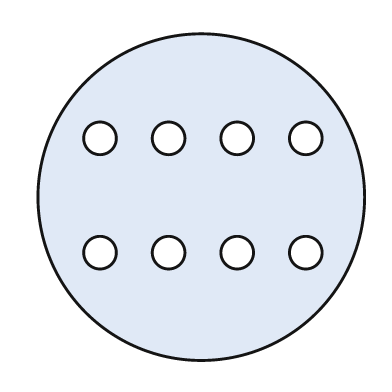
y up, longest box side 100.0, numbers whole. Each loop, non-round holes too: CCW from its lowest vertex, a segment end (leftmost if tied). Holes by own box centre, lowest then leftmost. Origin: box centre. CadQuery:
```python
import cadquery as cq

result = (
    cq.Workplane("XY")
    .moveTo(0.0, 0.0)
    .circle(50.0)
    .moveTo(-31.0, -17.0)
    .circle(5.0)
    .moveTo(-10.0, -17.0)
    .circle(5.0)
    .moveTo(11.0, -17.0)
    .circle(5.0)
    .moveTo(32.0, -17.0)
    .circle(5.0)
    .moveTo(-31.0, 18.0)
    .circle(5.0)
    .moveTo(-10.0, 18.0)
    .circle(5.0)
    .moveTo(11.0, 18.0)
    .circle(5.0)
    .moveTo(32.0, 18.0)
    .circle(5.0)
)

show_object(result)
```